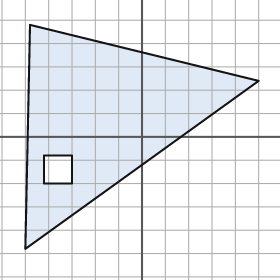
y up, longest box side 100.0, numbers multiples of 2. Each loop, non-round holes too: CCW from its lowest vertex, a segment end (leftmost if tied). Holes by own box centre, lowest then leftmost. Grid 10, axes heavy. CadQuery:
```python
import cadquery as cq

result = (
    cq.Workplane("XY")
    .moveTo(-50.0, -48.0)
    .lineTo(50.0, 24.0)
    .lineTo(-48.0, 48.0)
    .close()
    .moveTo(-42.0, -20.0)
    .lineTo(-30.0, -20.0)
    .lineTo(-30.0, -8.0)
    .lineTo(-42.0, -8.0)
    .close()
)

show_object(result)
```